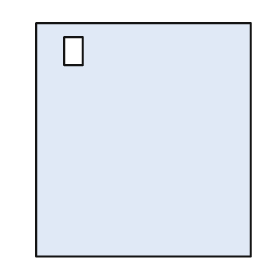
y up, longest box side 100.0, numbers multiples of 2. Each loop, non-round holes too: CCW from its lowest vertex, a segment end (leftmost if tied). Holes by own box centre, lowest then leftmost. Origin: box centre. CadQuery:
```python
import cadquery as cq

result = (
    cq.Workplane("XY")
    .moveTo(-46.0, -50.0)
    .lineTo(46.0, -50.0)
    .lineTo(46.0, 50.0)
    .lineTo(-46.0, 50.0)
    .close()
    .moveTo(-34.0, 32.0)
    .lineTo(-26.0, 32.0)
    .lineTo(-26.0, 44.0)
    .lineTo(-34.0, 44.0)
    .close()
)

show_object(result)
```